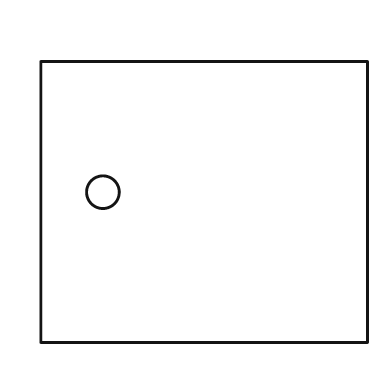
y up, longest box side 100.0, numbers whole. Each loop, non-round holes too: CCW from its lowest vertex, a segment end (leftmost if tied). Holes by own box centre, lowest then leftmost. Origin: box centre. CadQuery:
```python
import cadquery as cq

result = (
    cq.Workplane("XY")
    .moveTo(-50.0, -43.0)
    .lineTo(50.0, -43.0)
    .lineTo(50.0, 43.0)
    .lineTo(-50.0, 43.0)
    .close()
    .moveTo(-31.0, 3.0)
    .circle(5.0)
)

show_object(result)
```